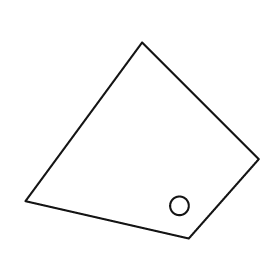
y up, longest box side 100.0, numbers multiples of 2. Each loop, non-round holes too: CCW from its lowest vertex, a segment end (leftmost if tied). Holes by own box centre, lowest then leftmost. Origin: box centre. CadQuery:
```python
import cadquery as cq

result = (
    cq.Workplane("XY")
    .moveTo(20.0, -42.0)
    .lineTo(50.0, -8.0)
    .lineTo(0.0, 42.0)
    .lineTo(-50.0, -26.0)
    .close()
    .moveTo(16.0, -28.0)
    .circle(4.0)
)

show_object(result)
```